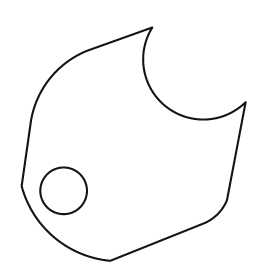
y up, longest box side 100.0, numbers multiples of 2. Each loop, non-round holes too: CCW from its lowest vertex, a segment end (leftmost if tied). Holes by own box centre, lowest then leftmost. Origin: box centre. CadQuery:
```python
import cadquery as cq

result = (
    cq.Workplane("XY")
    .moveTo(-10.0, -50.0)
    .lineTo(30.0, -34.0)
    .threePointArc((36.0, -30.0), (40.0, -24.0))
    .lineTo(48.0, 18.0)
    .threePointArc((14.0, 16.0), (8.0, 50.0))
    .lineTo(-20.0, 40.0)
    .threePointArc((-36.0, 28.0), (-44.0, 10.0))
    .lineTo(-48.0, -18.0)
    .threePointArc((-34.0, -40.0), (-10.0, -50.0))
    .close()
    .moveTo(-30.0, -20.0)
    .circle(10.0)
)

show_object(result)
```